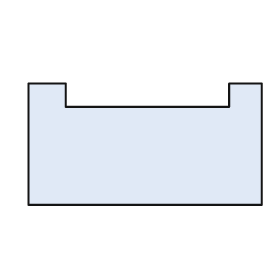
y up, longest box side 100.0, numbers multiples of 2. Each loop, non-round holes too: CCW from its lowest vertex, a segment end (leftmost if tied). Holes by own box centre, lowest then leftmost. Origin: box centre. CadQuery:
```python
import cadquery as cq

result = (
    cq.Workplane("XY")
    .moveTo(-50.0, -26.0)
    .lineTo(50.0, -26.0)
    .lineTo(50.0, 26.0)
    .lineTo(36.0, 26.0)
    .lineTo(36.0, 16.0)
    .lineTo(-34.0, 16.0)
    .lineTo(-34.0, 26.0)
    .lineTo(-50.0, 26.0)
    .close()
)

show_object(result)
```